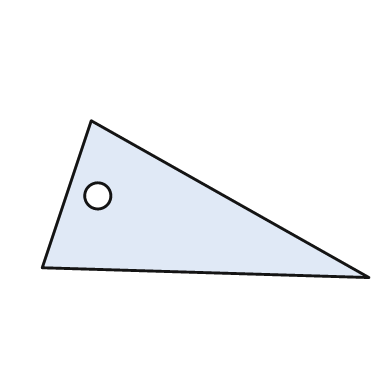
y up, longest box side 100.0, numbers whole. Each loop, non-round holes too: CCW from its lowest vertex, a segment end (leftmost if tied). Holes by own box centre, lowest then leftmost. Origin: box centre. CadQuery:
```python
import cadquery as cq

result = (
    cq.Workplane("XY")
    .moveTo(50.0, -24.0)
    .lineTo(-35.0, 24.0)
    .lineTo(-50.0, -21.0)
    .close()
    .moveTo(-33.0, 1.0)
    .circle(4.0)
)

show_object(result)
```